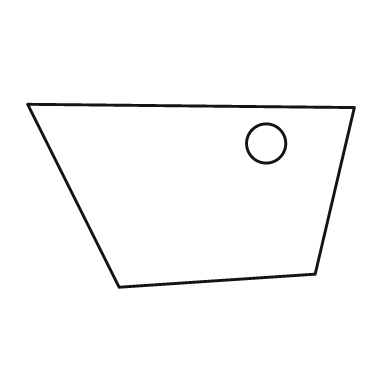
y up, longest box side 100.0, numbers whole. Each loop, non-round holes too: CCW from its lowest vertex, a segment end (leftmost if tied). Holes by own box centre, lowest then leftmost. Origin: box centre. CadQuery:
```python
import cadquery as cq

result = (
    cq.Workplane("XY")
    .moveTo(-22.0, -28.0)
    .lineTo(38.0, -24.0)
    .lineTo(50.0, 27.0)
    .lineTo(-50.0, 28.0)
    .close()
    .moveTo(23.0, 16.0)
    .circle(6.0)
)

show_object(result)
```